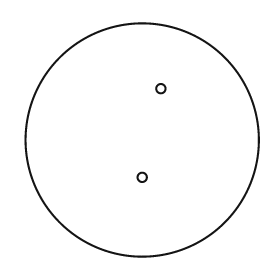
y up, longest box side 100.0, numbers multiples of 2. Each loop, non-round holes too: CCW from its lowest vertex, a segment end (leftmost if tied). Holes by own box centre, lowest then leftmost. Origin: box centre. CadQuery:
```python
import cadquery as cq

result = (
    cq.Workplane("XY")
    .moveTo(0.0, 0.0)
    .circle(50.0)
    .moveTo(0.0, -16.0)
    .circle(2.0)
    .moveTo(8.0, 22.0)
    .circle(2.0)
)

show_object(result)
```